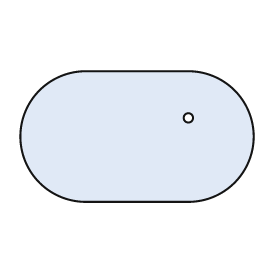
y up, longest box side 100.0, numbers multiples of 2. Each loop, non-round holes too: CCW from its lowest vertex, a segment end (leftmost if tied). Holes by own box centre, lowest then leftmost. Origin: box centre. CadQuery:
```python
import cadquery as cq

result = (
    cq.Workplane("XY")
    .moveTo(-22.0, -28.0)
    .lineTo(22.0, -28.0)
    .threePointArc((50.0, 0.0), (22.0, 28.0))
    .lineTo(-22.0, 28.0)
    .threePointArc((-50.0, 0.0), (-22.0, -28.0))
    .close()
    .moveTo(22.0, 8.0)
    .circle(2.0)
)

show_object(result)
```